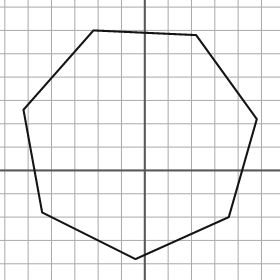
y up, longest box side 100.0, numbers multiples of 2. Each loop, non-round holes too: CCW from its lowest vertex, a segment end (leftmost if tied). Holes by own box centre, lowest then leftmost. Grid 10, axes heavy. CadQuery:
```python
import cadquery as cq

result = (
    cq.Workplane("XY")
    .moveTo(-4.0, -38.0)
    .lineTo(36.0, -20.0)
    .lineTo(48.0, 22.0)
    .lineTo(22.0, 58.0)
    .lineTo(-22.0, 60.0)
    .lineTo(-52.0, 26.0)
    .lineTo(-44.0, -18.0)
    .close()
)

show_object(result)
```